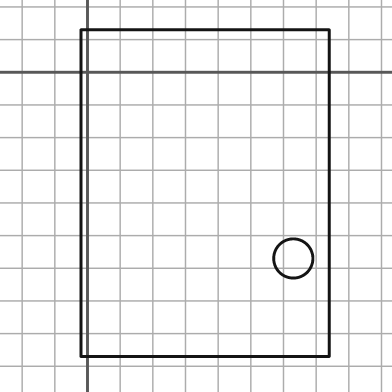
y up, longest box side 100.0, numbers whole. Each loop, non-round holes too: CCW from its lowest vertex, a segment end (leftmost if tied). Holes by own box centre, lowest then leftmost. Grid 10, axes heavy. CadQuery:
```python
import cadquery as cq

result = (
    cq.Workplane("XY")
    .moveTo(-2.0, -87.0)
    .lineTo(74.0, -87.0)
    .lineTo(74.0, 13.0)
    .lineTo(-2.0, 13.0)
    .close()
    .moveTo(63.0, -57.0)
    .circle(6.0)
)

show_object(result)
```